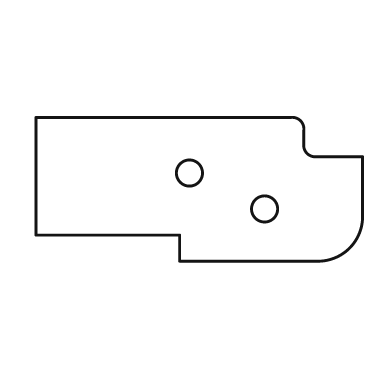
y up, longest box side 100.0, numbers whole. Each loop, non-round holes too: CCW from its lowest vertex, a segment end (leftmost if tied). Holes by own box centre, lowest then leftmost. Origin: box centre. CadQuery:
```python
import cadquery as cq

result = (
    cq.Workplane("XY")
    .moveTo(-6.0, -22.0)
    .lineTo(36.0, -22.0)
    .threePointArc((46.0, -18.0), (50.0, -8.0))
    .lineTo(50.0, 10.0)
    .lineTo(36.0, 10.0)
    .threePointArc((33.0, 11.0), (32.0, 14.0))
    .lineTo(32.0, 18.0)
    .threePointArc((31.0, 21.0), (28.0, 22.0))
    .lineTo(-50.0, 22.0)
    .lineTo(-50.0, -14.0)
    .lineTo(-6.0, -14.0)
    .close()
    .moveTo(20.0, -6.0)
    .circle(4.0)
    .moveTo(-3.0, 5.0)
    .circle(4.0)
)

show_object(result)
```